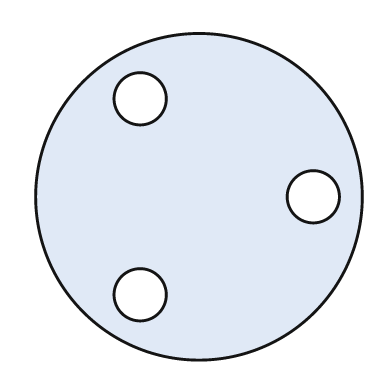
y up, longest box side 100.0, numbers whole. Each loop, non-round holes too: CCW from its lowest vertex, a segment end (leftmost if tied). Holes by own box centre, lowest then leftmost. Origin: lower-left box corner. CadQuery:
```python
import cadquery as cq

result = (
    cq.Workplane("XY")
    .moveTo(50.0, 50.0)
    .circle(50.0)
    .moveTo(32.0, 20.0)
    .circle(8.0)
    .moveTo(85.0, 50.0)
    .circle(8.0)
    .moveTo(32.0, 80.0)
    .circle(8.0)
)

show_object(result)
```